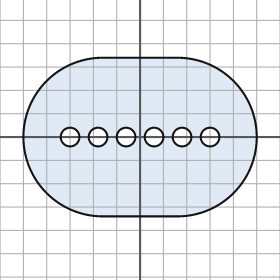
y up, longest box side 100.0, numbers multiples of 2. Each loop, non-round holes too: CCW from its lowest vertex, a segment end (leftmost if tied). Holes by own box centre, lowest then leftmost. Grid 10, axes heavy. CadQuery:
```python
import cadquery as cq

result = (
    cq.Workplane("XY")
    .moveTo(-16.0, -34.0)
    .lineTo(16.0, -34.0)
    .threePointArc((50.0, 0.0), (16.0, 34.0))
    .lineTo(-16.0, 34.0)
    .threePointArc((-50.0, 0.0), (-16.0, -34.0))
    .close()
    .moveTo(-30.0, 0.0)
    .circle(4.0)
    .moveTo(-18.0, 0.0)
    .circle(4.0)
    .moveTo(-6.0, 0.0)
    .circle(4.0)
    .moveTo(6.0, 0.0)
    .circle(4.0)
    .moveTo(18.0, 0.0)
    .circle(4.0)
    .moveTo(30.0, 0.0)
    .circle(4.0)
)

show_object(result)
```